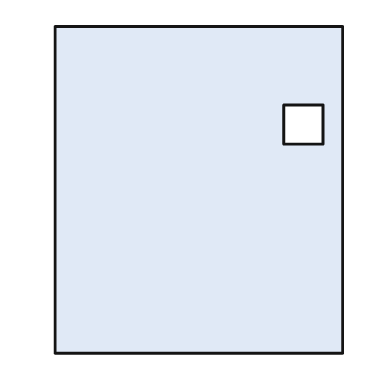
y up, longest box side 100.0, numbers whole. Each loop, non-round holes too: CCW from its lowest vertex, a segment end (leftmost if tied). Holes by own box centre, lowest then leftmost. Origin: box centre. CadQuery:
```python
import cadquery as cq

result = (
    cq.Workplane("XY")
    .moveTo(-44.0, -50.0)
    .lineTo(44.0, -50.0)
    .lineTo(44.0, 50.0)
    .lineTo(-44.0, 50.0)
    .close()
    .moveTo(26.0, 14.0)
    .lineTo(38.0, 14.0)
    .lineTo(38.0, 26.0)
    .lineTo(26.0, 26.0)
    .close()
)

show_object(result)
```